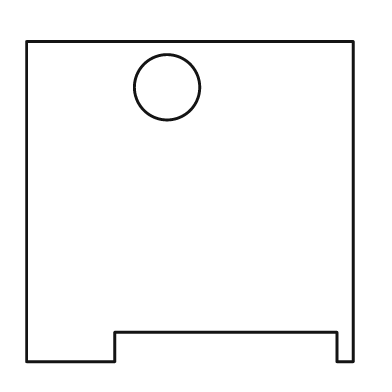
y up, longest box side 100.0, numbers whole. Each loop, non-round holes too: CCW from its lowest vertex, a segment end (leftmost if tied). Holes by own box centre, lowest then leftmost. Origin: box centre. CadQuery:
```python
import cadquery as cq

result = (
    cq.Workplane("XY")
    .moveTo(-50.0, -49.0)
    .lineTo(-23.0, -49.0)
    .lineTo(-23.0, -40.0)
    .lineTo(45.0, -40.0)
    .lineTo(45.0, -49.0)
    .lineTo(50.0, -49.0)
    .lineTo(50.0, 49.0)
    .lineTo(-50.0, 49.0)
    .close()
    .moveTo(-7.0, 35.0)
    .circle(10.0)
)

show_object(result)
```